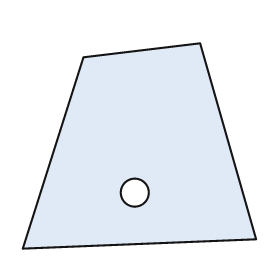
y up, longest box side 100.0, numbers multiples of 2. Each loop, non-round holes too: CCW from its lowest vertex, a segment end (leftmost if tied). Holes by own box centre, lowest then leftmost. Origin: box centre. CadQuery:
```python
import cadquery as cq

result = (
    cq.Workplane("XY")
    .moveTo(-50.0, -44.0)
    .lineTo(50.0, -40.0)
    .lineTo(26.0, 44.0)
    .lineTo(-24.0, 38.0)
    .close()
    .moveTo(-2.0, -20.0)
    .circle(6.0)
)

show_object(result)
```